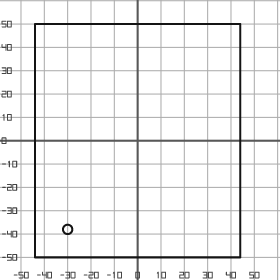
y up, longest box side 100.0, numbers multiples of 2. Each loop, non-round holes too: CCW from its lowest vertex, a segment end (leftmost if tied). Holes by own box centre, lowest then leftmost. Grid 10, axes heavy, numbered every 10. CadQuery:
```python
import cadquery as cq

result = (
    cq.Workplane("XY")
    .moveTo(-44.0, -50.0)
    .lineTo(44.0, -50.0)
    .lineTo(44.0, 50.0)
    .lineTo(-44.0, 50.0)
    .close()
    .moveTo(-30.0, -38.0)
    .circle(2.0)
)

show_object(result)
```